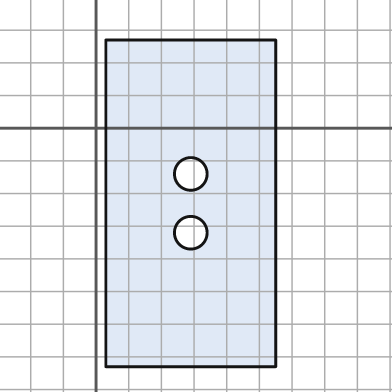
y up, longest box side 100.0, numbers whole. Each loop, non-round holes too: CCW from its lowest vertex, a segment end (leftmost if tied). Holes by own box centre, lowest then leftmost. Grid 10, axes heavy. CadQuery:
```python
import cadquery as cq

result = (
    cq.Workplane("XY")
    .moveTo(3.0, -73.0)
    .lineTo(55.0, -73.0)
    .lineTo(55.0, 27.0)
    .lineTo(3.0, 27.0)
    .close()
    .moveTo(29.0, -32.0)
    .circle(5.0)
    .moveTo(29.0, -14.0)
    .circle(5.0)
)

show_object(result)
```